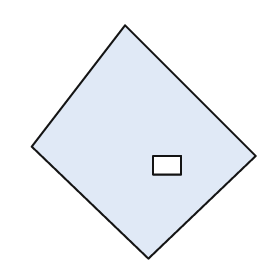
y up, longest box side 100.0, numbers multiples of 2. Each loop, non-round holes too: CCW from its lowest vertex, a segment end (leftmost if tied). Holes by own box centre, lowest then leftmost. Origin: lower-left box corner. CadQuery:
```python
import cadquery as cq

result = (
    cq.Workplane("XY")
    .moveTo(50.0, 0.0)
    .lineTo(96.0, 44.0)
    .lineTo(40.0, 100.0)
    .lineTo(0.0, 48.0)
    .close()
    .moveTo(52.0, 36.0)
    .lineTo(64.0, 36.0)
    .lineTo(64.0, 44.0)
    .lineTo(52.0, 44.0)
    .close()
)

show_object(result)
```